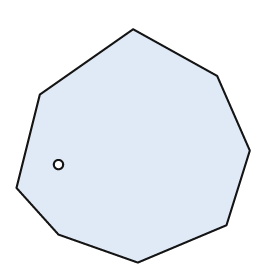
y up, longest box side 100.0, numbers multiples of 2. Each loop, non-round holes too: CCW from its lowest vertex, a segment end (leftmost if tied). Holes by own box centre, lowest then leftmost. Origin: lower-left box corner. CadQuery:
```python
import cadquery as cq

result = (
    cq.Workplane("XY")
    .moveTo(52.0, 0.0)
    .lineTo(90.0, 16.0)
    .lineTo(100.0, 48.0)
    .lineTo(86.0, 80.0)
    .lineTo(50.0, 100.0)
    .lineTo(10.0, 72.0)
    .lineTo(0.0, 32.0)
    .lineTo(18.0, 12.0)
    .close()
    .moveTo(18.0, 42.0)
    .circle(2.0)
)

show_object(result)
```